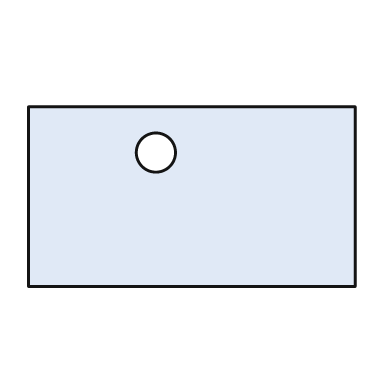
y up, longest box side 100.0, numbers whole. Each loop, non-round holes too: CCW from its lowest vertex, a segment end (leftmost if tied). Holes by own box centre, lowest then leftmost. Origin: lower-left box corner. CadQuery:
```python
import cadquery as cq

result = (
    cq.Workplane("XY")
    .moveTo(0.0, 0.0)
    .lineTo(100.0, 0.0)
    .lineTo(100.0, 55.0)
    .lineTo(0.0, 55.0)
    .close()
    .moveTo(39.0, 41.0)
    .circle(6.0)
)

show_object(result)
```